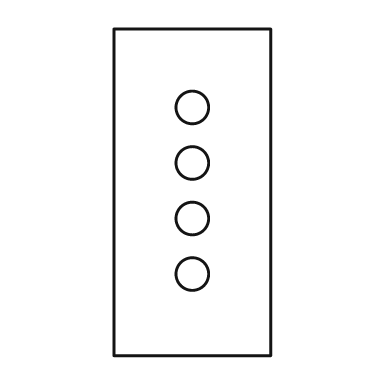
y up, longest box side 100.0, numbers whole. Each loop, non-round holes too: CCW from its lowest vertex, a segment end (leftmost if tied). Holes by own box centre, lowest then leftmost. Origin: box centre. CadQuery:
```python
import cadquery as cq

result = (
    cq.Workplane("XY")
    .moveTo(-24.0, -50.0)
    .lineTo(24.0, -50.0)
    .lineTo(24.0, 50.0)
    .lineTo(-24.0, 50.0)
    .close()
    .moveTo(0.0, -25.0)
    .circle(5.0)
    .moveTo(0.0, -8.0)
    .circle(5.0)
    .moveTo(0.0, 9.0)
    .circle(5.0)
    .moveTo(0.0, 26.0)
    .circle(5.0)
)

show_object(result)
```